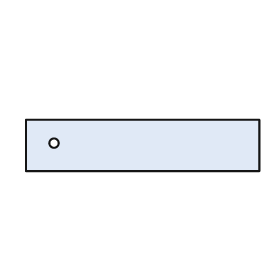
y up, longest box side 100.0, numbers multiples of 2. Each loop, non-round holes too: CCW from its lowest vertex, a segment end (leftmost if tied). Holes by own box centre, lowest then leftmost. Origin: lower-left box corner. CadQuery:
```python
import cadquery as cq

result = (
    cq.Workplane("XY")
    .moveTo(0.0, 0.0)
    .lineTo(100.0, 0.0)
    .lineTo(100.0, 22.0)
    .lineTo(0.0, 22.0)
    .close()
    .moveTo(12.0, 12.0)
    .circle(2.0)
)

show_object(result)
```